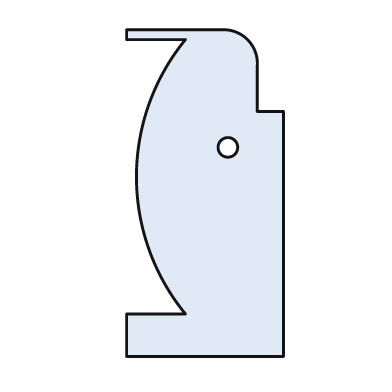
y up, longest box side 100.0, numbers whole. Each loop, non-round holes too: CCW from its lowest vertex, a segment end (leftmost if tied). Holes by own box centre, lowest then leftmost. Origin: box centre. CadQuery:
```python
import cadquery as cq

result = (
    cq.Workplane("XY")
    .moveTo(-24.0, -50.0)
    .lineTo(24.0, -50.0)
    .lineTo(24.0, 25.0)
    .lineTo(16.0, 25.0)
    .lineTo(16.0, 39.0)
    .threePointArc((13.0, 47.0), (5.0, 50.0))
    .lineTo(-24.0, 50.0)
    .lineTo(-24.0, 47.0)
    .lineTo(-6.0, 47.0)
    .threePointArc((-21.0, 5.0), (-6.0, -37.0))
    .lineTo(-24.0, -37.0)
    .close()
    .moveTo(7.0, 14.0)
    .circle(3.0)
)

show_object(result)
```